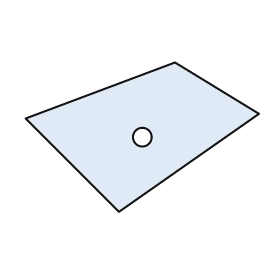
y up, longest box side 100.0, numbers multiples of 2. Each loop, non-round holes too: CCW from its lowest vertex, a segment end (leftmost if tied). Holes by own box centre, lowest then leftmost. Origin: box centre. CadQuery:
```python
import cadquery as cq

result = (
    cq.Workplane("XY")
    .moveTo(-10.0, -32.0)
    .lineTo(50.0, 10.0)
    .lineTo(14.0, 32.0)
    .lineTo(-50.0, 8.0)
    .close()
    .moveTo(0.0, 0.0)
    .circle(4.0)
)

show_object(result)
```